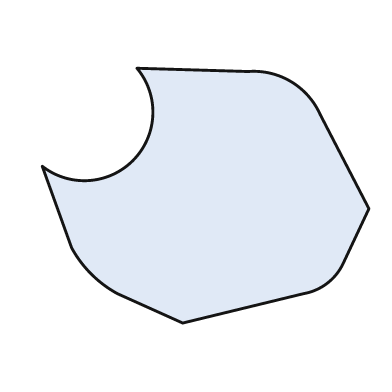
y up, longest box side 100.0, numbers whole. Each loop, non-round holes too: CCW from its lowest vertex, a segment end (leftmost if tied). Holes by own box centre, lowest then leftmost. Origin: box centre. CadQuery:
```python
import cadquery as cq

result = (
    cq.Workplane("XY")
    .moveTo(-7.0, -39.0)
    .lineTo(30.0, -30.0)
    .threePointArc((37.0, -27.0), (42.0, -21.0))
    .lineTo(50.0, -4.0)
    .lineTo(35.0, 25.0)
    .threePointArc((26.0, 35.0), (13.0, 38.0))
    .lineTo(-21.0, 39.0)
    .threePointArc((-22.0, 11.0), (-50.0, 9.0))
    .lineTo(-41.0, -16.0)
    .threePointArc((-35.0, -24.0), (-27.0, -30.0))
    .close()
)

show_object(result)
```